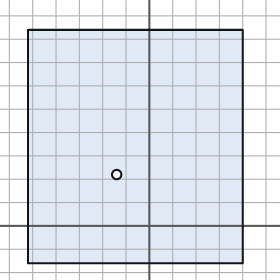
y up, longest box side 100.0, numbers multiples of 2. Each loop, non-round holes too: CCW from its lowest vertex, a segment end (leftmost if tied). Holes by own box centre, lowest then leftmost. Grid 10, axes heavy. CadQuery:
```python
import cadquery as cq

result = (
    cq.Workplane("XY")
    .moveTo(-52.0, -16.0)
    .lineTo(40.0, -16.0)
    .lineTo(40.0, 84.0)
    .lineTo(-52.0, 84.0)
    .close()
    .moveTo(-14.0, 22.0)
    .circle(2.0)
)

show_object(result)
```